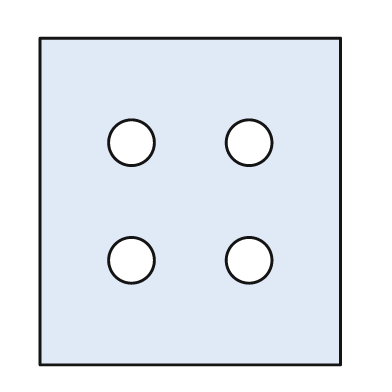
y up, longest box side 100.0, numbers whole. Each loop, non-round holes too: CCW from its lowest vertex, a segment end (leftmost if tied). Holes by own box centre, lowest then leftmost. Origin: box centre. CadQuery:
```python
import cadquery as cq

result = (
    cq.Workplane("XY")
    .moveTo(-46.0, -50.0)
    .lineTo(46.0, -50.0)
    .lineTo(46.0, 50.0)
    .lineTo(-46.0, 50.0)
    .close()
    .moveTo(-18.0, -18.0)
    .circle(7.0)
    .moveTo(18.0, -18.0)
    .circle(7.0)
    .moveTo(-18.0, 18.0)
    .circle(7.0)
    .moveTo(18.0, 18.0)
    .circle(7.0)
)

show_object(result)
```